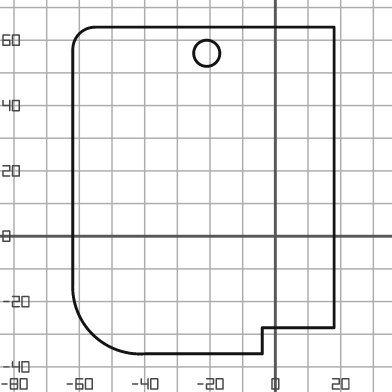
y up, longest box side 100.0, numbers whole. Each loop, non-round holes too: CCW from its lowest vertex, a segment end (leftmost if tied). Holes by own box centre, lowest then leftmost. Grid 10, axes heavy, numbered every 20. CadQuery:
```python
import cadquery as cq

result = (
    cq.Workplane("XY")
    .moveTo(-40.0, -36.0)
    .lineTo(-4.0, -36.0)
    .lineTo(-4.0, -28.0)
    .lineTo(18.0, -28.0)
    .lineTo(18.0, 64.0)
    .lineTo(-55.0, 64.0)
    .threePointArc((-60.0, 62.0), (-62.0, 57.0))
    .lineTo(-62.0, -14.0)
    .threePointArc((-56.0, -30.0), (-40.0, -36.0))
    .close()
    .moveTo(-21.0, 56.0)
    .circle(4.0)
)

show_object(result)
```